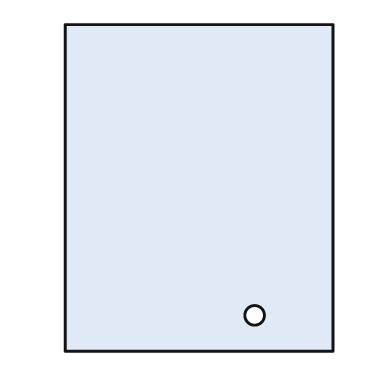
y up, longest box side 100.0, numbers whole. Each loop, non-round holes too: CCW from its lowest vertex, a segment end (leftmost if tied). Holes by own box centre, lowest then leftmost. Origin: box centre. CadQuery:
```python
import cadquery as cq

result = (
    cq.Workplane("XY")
    .moveTo(-41.0, -50.0)
    .lineTo(41.0, -50.0)
    .lineTo(41.0, 50.0)
    .lineTo(-41.0, 50.0)
    .close()
    .moveTo(17.0, -39.0)
    .circle(3.0)
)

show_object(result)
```